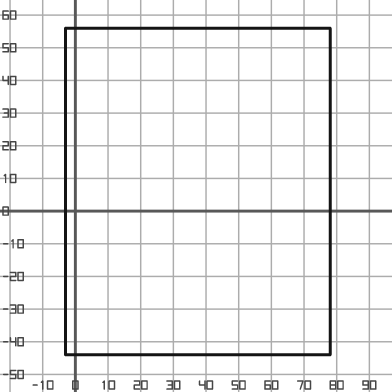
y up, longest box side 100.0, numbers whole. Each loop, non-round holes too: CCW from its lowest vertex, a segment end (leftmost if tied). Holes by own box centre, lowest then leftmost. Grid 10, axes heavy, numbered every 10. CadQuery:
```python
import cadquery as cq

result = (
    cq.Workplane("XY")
    .moveTo(-3.0, -44.0)
    .lineTo(78.0, -44.0)
    .lineTo(78.0, 56.0)
    .lineTo(-3.0, 56.0)
    .close()
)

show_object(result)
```